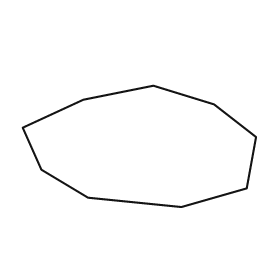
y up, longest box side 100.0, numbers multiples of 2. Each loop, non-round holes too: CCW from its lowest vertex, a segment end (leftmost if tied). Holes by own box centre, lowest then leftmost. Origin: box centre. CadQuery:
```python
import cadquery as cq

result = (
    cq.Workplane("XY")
    .moveTo(18.0, -26.0)
    .lineTo(46.0, -18.0)
    .lineTo(50.0, 4.0)
    .lineTo(32.0, 18.0)
    .lineTo(6.0, 26.0)
    .lineTo(-24.0, 20.0)
    .lineTo(-50.0, 8.0)
    .lineTo(-42.0, -10.0)
    .lineTo(-22.0, -22.0)
    .close()
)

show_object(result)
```